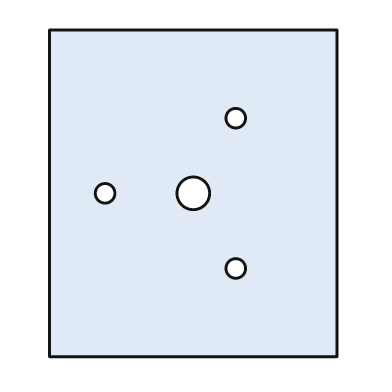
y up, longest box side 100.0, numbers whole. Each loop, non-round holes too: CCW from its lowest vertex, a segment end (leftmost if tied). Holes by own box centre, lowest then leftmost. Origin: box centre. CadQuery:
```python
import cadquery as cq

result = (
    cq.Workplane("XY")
    .moveTo(-44.0, -50.0)
    .lineTo(44.0, -50.0)
    .lineTo(44.0, 50.0)
    .lineTo(-44.0, 50.0)
    .close()
    .moveTo(13.0, -23.0)
    .circle(3.0)
    .moveTo(-27.0, 0.0)
    .circle(3.0)
    .moveTo(0.0, 0.0)
    .circle(5.0)
    .moveTo(13.0, 23.0)
    .circle(3.0)
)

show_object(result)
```